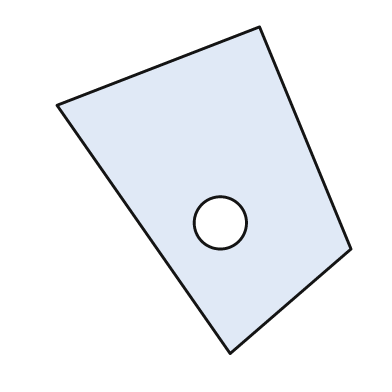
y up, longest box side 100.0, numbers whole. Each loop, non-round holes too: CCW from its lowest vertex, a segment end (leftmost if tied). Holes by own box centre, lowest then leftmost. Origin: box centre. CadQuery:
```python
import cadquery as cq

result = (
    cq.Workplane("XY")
    .moveTo(8.0, -50.0)
    .lineTo(45.0, -18.0)
    .lineTo(17.0, 50.0)
    .lineTo(-45.0, 26.0)
    .close()
    .moveTo(5.0, -10.0)
    .circle(8.0)
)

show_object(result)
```